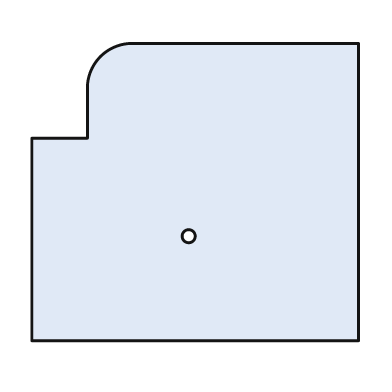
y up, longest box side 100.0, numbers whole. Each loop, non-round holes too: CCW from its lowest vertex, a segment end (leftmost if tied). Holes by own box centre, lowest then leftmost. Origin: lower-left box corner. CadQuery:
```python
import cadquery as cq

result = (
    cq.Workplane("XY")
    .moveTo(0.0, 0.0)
    .lineTo(100.0, 0.0)
    .lineTo(100.0, 91.0)
    .lineTo(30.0, 91.0)
    .threePointArc((21.0, 87.0), (17.0, 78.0))
    .lineTo(17.0, 62.0)
    .lineTo(0.0, 62.0)
    .close()
    .moveTo(48.0, 32.0)
    .circle(2.0)
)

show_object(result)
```